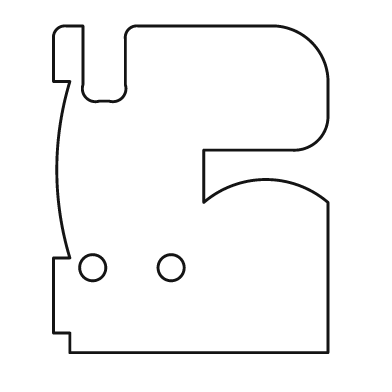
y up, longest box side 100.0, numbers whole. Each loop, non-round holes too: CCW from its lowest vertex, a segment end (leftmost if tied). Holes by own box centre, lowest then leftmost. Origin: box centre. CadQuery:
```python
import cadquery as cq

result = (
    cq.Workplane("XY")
    .moveTo(-37.0, -50.0)
    .lineTo(42.0, -50.0)
    .lineTo(42.0, -4.0)
    .threePointArc((23.0, 3.0), (4.0, -4.0))
    .lineTo(4.0, 12.0)
    .lineTo(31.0, 12.0)
    .threePointArc((39.0, 15.0), (42.0, 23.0))
    .lineTo(42.0, 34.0)
    .threePointArc((37.0, 45.0), (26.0, 50.0))
    .lineTo(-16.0, 50.0)
    .threePointArc((-19.0, 49.0), (-20.0, 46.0))
    .lineTo(-20.0, 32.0)
    .threePointArc((-21.0, 28.0), (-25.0, 27.0))
    .lineTo(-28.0, 27.0)
    .threePointArc((-32.0, 28.0), (-33.0, 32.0))
    .lineTo(-33.0, 50.0)
    .lineTo(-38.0, 50.0)
    .threePointArc((-41.0, 49.0), (-42.0, 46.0))
    .lineTo(-42.0, 33.0)
    .lineTo(-37.0, 33.0)
    .threePointArc((-41.0, 6.0), (-37.0, -21.0))
    .lineTo(-42.0, -21.0)
    .lineTo(-42.0, -44.0)
    .lineTo(-37.0, -44.0)
    .close()
    .moveTo(-30.0, -24.0)
    .circle(4.0)
    .moveTo(-6.0, -24.0)
    .circle(4.0)
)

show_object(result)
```